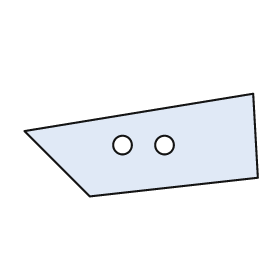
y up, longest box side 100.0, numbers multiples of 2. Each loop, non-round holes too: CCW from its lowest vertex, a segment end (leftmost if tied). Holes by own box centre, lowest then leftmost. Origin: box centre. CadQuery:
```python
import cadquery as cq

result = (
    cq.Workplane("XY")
    .moveTo(-22.0, -22.0)
    .lineTo(50.0, -14.0)
    .lineTo(48.0, 22.0)
    .lineTo(-50.0, 6.0)
    .close()
    .moveTo(-8.0, 0.0)
    .circle(4.0)
    .moveTo(10.0, 0.0)
    .circle(4.0)
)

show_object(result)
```